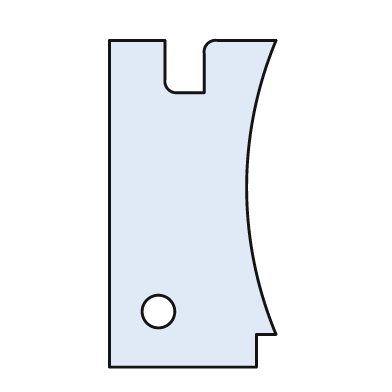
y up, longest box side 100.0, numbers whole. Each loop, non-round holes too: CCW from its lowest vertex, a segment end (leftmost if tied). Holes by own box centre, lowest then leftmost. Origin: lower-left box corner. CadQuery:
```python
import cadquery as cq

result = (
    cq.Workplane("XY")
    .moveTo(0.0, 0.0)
    .lineTo(45.0, 0.0)
    .lineTo(45.0, 10.0)
    .lineTo(51.0, 10.0)
    .threePointArc((42.0, 55.0), (51.0, 100.0))
    .lineTo(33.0, 100.0)
    .threePointArc((30.0, 99.0), (29.0, 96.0))
    .lineTo(29.0, 84.0)
    .lineTo(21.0, 84.0)
    .threePointArc((18.0, 85.0), (17.0, 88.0))
    .lineTo(17.0, 100.0)
    .lineTo(0.0, 100.0)
    .close()
    .moveTo(15.0, 17.0)
    .circle(5.0)
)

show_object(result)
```